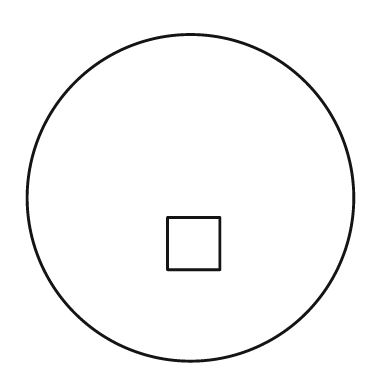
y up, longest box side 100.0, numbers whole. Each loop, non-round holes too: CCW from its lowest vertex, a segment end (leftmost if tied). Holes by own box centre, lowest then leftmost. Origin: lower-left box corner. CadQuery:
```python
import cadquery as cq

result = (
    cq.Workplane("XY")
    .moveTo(50.0, 50.0)
    .circle(50.0)
    .moveTo(43.0, 28.0)
    .lineTo(59.0, 28.0)
    .lineTo(59.0, 44.0)
    .lineTo(43.0, 44.0)
    .close()
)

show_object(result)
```